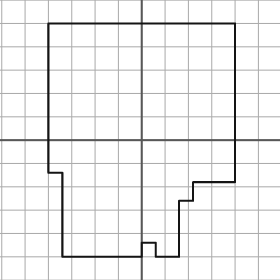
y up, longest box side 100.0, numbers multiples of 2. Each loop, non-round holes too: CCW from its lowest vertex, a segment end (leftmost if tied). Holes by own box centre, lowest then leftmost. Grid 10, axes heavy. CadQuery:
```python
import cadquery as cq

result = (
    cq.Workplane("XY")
    .moveTo(-34.0, -50.0)
    .lineTo(0.0, -50.0)
    .lineTo(0.0, -44.0)
    .lineTo(6.0, -44.0)
    .lineTo(6.0, -50.0)
    .lineTo(16.0, -50.0)
    .lineTo(16.0, -26.0)
    .lineTo(22.0, -26.0)
    .lineTo(22.0, -18.0)
    .lineTo(40.0, -18.0)
    .lineTo(40.0, 50.0)
    .lineTo(-40.0, 50.0)
    .lineTo(-40.0, -14.0)
    .lineTo(-34.0, -14.0)
    .close()
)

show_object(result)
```